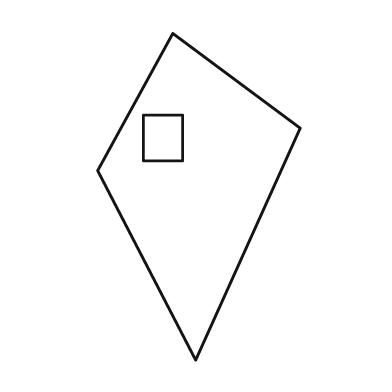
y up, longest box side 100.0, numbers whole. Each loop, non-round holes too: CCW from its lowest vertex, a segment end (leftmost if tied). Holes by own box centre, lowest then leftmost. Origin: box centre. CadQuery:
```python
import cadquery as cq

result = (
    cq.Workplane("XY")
    .moveTo(-1.0, -50.0)
    .lineTo(31.0, 21.0)
    .lineTo(-8.0, 50.0)
    .lineTo(-31.0, 8.0)
    .close()
    .moveTo(-17.0, 11.0)
    .lineTo(-5.0, 11.0)
    .lineTo(-5.0, 25.0)
    .lineTo(-17.0, 25.0)
    .close()
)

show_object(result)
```